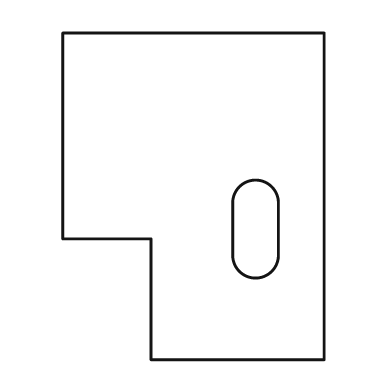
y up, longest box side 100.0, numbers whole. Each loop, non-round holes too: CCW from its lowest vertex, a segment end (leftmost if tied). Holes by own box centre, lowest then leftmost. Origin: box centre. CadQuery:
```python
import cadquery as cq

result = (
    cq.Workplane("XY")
    .moveTo(-13.0, -50.0)
    .lineTo(40.0, -50.0)
    .lineTo(40.0, 50.0)
    .lineTo(-40.0, 50.0)
    .lineTo(-40.0, -13.0)
    .lineTo(-13.0, -13.0)
    .close()
    .moveTo(12.0, -18.0)
    .threePointArc((19.0, -25.0), (26.0, -18.0))
    .lineTo(26.0, -2.0)
    .threePointArc((19.0, 5.0), (12.0, -2.0))
    .close()
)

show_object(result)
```